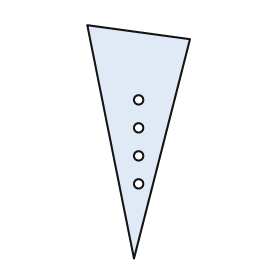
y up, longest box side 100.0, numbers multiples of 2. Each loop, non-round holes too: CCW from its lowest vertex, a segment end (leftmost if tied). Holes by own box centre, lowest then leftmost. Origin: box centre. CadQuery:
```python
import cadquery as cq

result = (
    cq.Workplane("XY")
    .moveTo(-2.0, -50.0)
    .lineTo(22.0, 44.0)
    .lineTo(-22.0, 50.0)
    .close()
    .moveTo(0.0, -18.0)
    .circle(2.0)
    .moveTo(0.0, -6.0)
    .circle(2.0)
    .moveTo(0.0, 6.0)
    .circle(2.0)
    .moveTo(0.0, 18.0)
    .circle(2.0)
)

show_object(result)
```